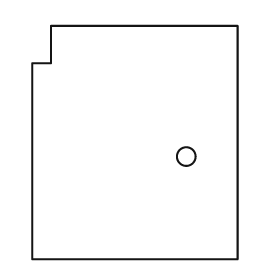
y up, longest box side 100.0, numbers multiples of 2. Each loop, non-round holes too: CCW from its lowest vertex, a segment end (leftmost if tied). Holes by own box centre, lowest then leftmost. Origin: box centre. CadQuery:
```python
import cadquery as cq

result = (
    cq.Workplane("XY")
    .moveTo(-44.0, -50.0)
    .lineTo(44.0, -50.0)
    .lineTo(44.0, 50.0)
    .lineTo(-36.0, 50.0)
    .lineTo(-36.0, 34.0)
    .lineTo(-44.0, 34.0)
    .close()
    .moveTo(22.0, -6.0)
    .circle(4.0)
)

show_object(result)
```